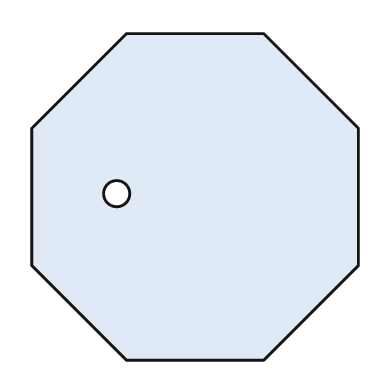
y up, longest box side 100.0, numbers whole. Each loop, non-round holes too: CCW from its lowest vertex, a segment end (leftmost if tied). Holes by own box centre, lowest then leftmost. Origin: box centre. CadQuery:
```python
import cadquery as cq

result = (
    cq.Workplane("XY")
    .moveTo(-21.0, -50.0)
    .lineTo(21.0, -50.0)
    .lineTo(50.0, -21.0)
    .lineTo(50.0, 21.0)
    .lineTo(21.0, 50.0)
    .lineTo(-21.0, 50.0)
    .lineTo(-50.0, 21.0)
    .lineTo(-50.0, -21.0)
    .close()
    .moveTo(-24.0, 1.0)
    .circle(4.0)
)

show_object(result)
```